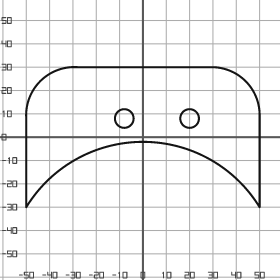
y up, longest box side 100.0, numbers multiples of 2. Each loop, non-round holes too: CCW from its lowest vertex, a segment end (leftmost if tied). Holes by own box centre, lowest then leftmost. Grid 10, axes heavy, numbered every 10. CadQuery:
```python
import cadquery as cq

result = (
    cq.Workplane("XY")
    .moveTo(-50.0, -30.0)
    .threePointArc((0.0, -2.0), (50.0, -30.0))
    .lineTo(50.0, 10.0)
    .threePointArc((44.0, 24.0), (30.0, 30.0))
    .lineTo(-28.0, 30.0)
    .threePointArc((-44.0, 24.0), (-50.0, 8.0))
    .close()
    .moveTo(-8.0, 8.0)
    .circle(4.0)
    .moveTo(20.0, 8.0)
    .circle(4.0)
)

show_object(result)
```